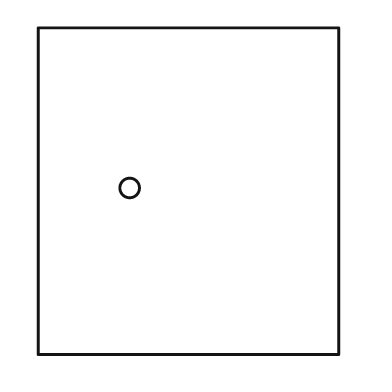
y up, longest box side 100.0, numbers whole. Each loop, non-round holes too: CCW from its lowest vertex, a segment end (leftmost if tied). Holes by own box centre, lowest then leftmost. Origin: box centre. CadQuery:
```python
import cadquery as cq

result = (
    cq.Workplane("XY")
    .moveTo(-46.0, -50.0)
    .lineTo(46.0, -50.0)
    .lineTo(46.0, 50.0)
    .lineTo(-46.0, 50.0)
    .close()
    .moveTo(-18.0, 1.0)
    .circle(3.0)
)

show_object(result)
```